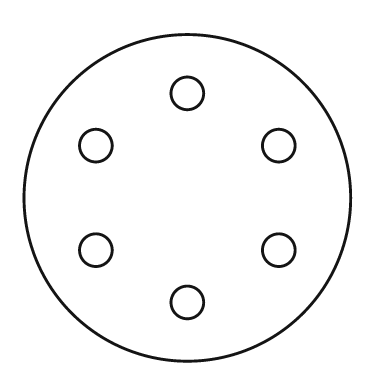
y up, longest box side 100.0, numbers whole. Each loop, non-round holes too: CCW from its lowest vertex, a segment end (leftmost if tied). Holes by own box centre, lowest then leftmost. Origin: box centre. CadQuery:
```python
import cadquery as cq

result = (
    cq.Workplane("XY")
    .moveTo(0.0, 0.0)
    .circle(50.0)
    .moveTo(0.0, -32.0)
    .circle(5.0)
    .moveTo(-28.0, -16.0)
    .circle(5.0)
    .moveTo(28.0, -16.0)
    .circle(5.0)
    .moveTo(-28.0, 16.0)
    .circle(5.0)
    .moveTo(28.0, 16.0)
    .circle(5.0)
    .moveTo(0.0, 32.0)
    .circle(5.0)
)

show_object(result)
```